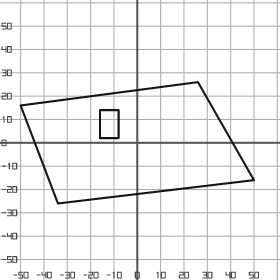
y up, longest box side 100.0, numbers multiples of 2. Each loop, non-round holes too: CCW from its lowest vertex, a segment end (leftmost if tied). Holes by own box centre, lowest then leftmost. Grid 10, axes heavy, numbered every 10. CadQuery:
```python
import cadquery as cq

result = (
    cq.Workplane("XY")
    .moveTo(-34.0, -26.0)
    .lineTo(50.0, -16.0)
    .lineTo(26.0, 26.0)
    .lineTo(-50.0, 16.0)
    .close()
    .moveTo(-16.0, 2.0)
    .lineTo(-8.0, 2.0)
    .lineTo(-8.0, 14.0)
    .lineTo(-16.0, 14.0)
    .close()
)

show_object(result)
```